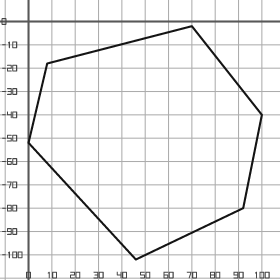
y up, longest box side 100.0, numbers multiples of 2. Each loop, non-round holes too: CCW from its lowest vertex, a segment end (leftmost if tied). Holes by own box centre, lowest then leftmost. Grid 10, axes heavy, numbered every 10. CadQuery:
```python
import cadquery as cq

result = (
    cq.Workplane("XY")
    .moveTo(46.0, -102.0)
    .lineTo(92.0, -80.0)
    .lineTo(100.0, -40.0)
    .lineTo(70.0, -2.0)
    .lineTo(8.0, -18.0)
    .lineTo(0.0, -52.0)
    .close()
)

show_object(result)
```